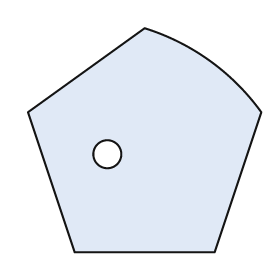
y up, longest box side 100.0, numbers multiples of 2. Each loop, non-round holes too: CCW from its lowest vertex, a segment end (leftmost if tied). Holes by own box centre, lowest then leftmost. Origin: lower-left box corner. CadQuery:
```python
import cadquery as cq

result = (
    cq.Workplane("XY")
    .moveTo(20.0, 0.0)
    .lineTo(80.0, 0.0)
    .lineTo(100.0, 60.0)
    .threePointArc((78.0, 82.0), (50.0, 96.0))
    .lineTo(0.0, 60.0)
    .close()
    .moveTo(34.0, 42.0)
    .circle(6.0)
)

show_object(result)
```